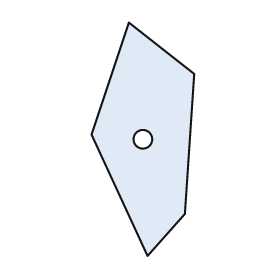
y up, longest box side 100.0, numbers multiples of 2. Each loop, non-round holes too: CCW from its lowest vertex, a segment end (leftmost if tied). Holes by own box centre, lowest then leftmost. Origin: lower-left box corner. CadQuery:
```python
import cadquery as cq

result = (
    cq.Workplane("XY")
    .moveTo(24.0, 0.0)
    .lineTo(40.0, 18.0)
    .lineTo(44.0, 78.0)
    .lineTo(16.0, 100.0)
    .lineTo(0.0, 52.0)
    .close()
    .moveTo(22.0, 50.0)
    .circle(4.0)
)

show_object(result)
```